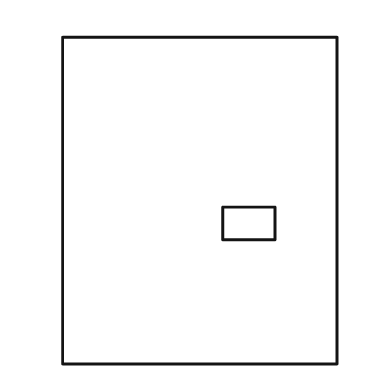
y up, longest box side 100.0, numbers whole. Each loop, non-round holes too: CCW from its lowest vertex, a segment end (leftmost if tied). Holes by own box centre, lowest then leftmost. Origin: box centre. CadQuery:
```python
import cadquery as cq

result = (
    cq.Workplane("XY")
    .moveTo(-42.0, -50.0)
    .lineTo(42.0, -50.0)
    .lineTo(42.0, 50.0)
    .lineTo(-42.0, 50.0)
    .close()
    .moveTo(7.0, -12.0)
    .lineTo(23.0, -12.0)
    .lineTo(23.0, -2.0)
    .lineTo(7.0, -2.0)
    .close()
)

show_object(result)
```